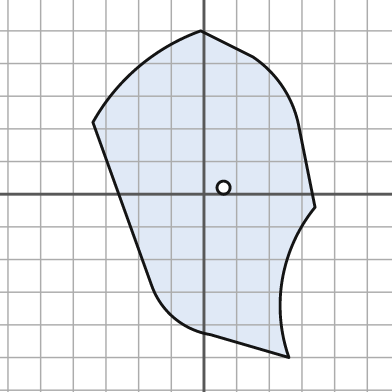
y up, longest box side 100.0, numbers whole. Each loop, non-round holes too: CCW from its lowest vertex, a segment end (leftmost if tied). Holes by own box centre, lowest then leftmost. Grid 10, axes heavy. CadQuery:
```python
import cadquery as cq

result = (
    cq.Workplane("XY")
    .moveTo(26.0, -50.0)
    .threePointArc((24.0, -26.0), (34.0, -4.0))
    .lineTo(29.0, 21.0)
    .threePointArc((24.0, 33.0), (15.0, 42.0))
    .lineTo(-1.0, 50.0)
    .threePointArc((-20.0, 39.0), (-34.0, 22.0))
    .lineTo(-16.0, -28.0)
    .threePointArc((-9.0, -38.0), (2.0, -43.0))
    .close()
    .moveTo(6.0, 2.0)
    .circle(2.0)
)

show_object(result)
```